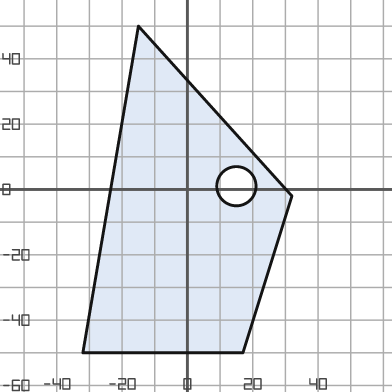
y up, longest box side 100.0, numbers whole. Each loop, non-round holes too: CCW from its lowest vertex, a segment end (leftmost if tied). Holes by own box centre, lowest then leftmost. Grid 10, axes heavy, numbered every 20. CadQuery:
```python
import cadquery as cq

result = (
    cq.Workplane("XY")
    .moveTo(-32.0, -50.0)
    .lineTo(17.0, -50.0)
    .lineTo(32.0, -2.0)
    .lineTo(-15.0, 50.0)
    .close()
    .moveTo(15.0, 1.0)
    .circle(6.0)
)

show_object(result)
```